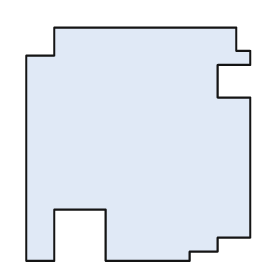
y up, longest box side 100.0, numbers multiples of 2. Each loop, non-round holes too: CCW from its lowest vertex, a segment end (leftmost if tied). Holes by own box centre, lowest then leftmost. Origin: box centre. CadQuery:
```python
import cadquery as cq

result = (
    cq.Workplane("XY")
    .moveTo(-48.0, -50.0)
    .lineTo(-36.0, -50.0)
    .lineTo(-36.0, -28.0)
    .lineTo(-14.0, -28.0)
    .lineTo(-14.0, -50.0)
    .lineTo(22.0, -50.0)
    .lineTo(22.0, -46.0)
    .lineTo(34.0, -46.0)
    .lineTo(34.0, -40.0)
    .lineTo(48.0, -40.0)
    .lineTo(48.0, 20.0)
    .lineTo(34.0, 20.0)
    .lineTo(34.0, 34.0)
    .lineTo(48.0, 34.0)
    .lineTo(48.0, 40.0)
    .lineTo(42.0, 40.0)
    .lineTo(42.0, 50.0)
    .lineTo(-36.0, 50.0)
    .lineTo(-36.0, 38.0)
    .lineTo(-48.0, 38.0)
    .close()
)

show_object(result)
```